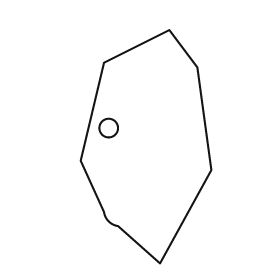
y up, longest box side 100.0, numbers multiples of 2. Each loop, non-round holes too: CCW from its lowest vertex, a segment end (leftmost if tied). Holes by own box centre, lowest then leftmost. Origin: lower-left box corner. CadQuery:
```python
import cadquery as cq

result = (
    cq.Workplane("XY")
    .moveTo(34.0, 0.0)
    .lineTo(56.0, 40.0)
    .lineTo(50.0, 84.0)
    .lineTo(38.0, 100.0)
    .lineTo(10.0, 86.0)
    .lineTo(0.0, 44.0)
    .lineTo(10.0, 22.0)
    .threePointArc((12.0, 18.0), (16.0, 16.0))
    .close()
    .moveTo(12.0, 58.0)
    .circle(4.0)
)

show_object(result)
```